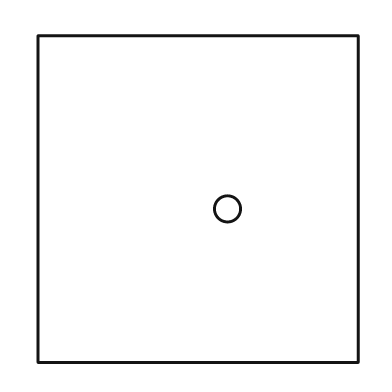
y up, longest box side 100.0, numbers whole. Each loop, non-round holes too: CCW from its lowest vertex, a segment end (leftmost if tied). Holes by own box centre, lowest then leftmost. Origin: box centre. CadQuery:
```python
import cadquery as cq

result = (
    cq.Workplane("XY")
    .moveTo(-49.0, -50.0)
    .lineTo(49.0, -50.0)
    .lineTo(49.0, 50.0)
    .lineTo(-49.0, 50.0)
    .close()
    .moveTo(9.0, -3.0)
    .circle(4.0)
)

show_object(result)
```